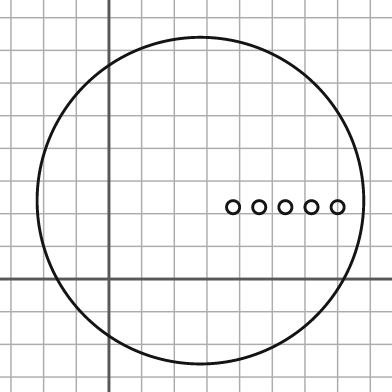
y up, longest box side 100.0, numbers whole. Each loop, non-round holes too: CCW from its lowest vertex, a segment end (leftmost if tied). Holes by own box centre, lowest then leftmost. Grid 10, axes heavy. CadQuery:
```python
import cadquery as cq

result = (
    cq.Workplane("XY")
    .moveTo(28.0, 24.0)
    .circle(50.0)
    .moveTo(38.0, 22.0)
    .circle(2.0)
    .moveTo(46.0, 22.0)
    .circle(2.0)
    .moveTo(54.0, 22.0)
    .circle(2.0)
    .moveTo(62.0, 22.0)
    .circle(2.0)
    .moveTo(70.0, 22.0)
    .circle(2.0)
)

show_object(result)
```